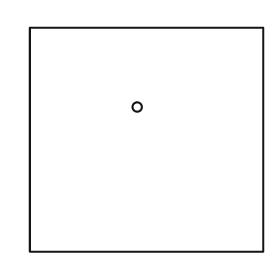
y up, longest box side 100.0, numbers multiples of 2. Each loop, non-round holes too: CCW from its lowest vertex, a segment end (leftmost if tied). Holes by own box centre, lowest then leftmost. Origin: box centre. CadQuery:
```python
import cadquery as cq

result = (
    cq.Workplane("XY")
    .moveTo(-50.0, -48.0)
    .lineTo(50.0, -48.0)
    .lineTo(50.0, 48.0)
    .lineTo(-50.0, 48.0)
    .close()
    .moveTo(-4.0, 14.0)
    .circle(2.0)
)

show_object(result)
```